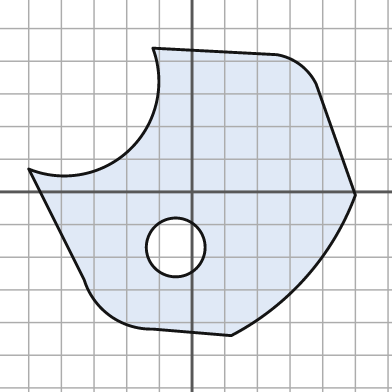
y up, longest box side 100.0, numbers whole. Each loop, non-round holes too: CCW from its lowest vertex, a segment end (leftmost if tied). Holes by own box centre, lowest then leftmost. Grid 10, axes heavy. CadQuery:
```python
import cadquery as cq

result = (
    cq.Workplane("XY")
    .moveTo(12.0, -44.0)
    .threePointArc((35.0, -26.0), (50.0, -1.0))
    .lineTo(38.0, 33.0)
    .threePointArc((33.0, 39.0), (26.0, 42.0))
    .lineTo(-12.0, 44.0)
    .threePointArc((-19.0, 13.0), (-50.0, 7.0))
    .lineTo(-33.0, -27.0)
    .threePointArc((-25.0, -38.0), (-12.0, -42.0))
    .close()
    .moveTo(-5.0, -17.0)
    .circle(9.0)
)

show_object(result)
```